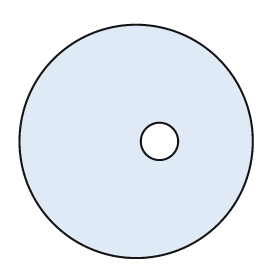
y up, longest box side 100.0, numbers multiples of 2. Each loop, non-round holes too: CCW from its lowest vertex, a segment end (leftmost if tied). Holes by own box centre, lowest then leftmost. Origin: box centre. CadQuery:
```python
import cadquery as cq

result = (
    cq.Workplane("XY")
    .moveTo(0.0, 0.0)
    .circle(50.0)
    .moveTo(10.0, 0.0)
    .circle(8.0)
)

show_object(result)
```